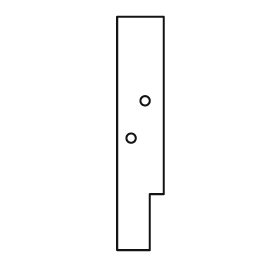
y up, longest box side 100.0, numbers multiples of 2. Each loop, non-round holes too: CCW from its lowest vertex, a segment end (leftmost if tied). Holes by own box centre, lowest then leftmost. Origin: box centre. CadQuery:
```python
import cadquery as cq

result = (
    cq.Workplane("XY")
    .moveTo(-10.0, -50.0)
    .lineTo(4.0, -50.0)
    .lineTo(4.0, -26.0)
    .lineTo(10.0, -26.0)
    .lineTo(10.0, 50.0)
    .lineTo(-10.0, 50.0)
    .close()
    .moveTo(-4.0, -2.0)
    .circle(2.0)
    .moveTo(2.0, 14.0)
    .circle(2.0)
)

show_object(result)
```